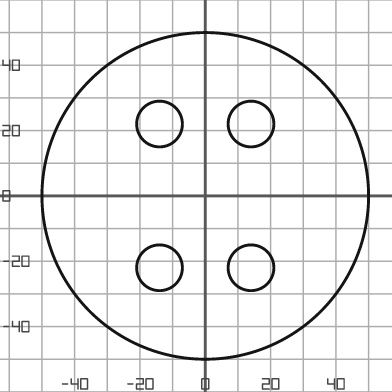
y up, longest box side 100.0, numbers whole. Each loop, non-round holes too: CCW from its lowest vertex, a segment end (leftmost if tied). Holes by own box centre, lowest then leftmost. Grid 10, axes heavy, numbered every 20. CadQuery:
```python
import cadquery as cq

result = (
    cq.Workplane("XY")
    .moveTo(0.0, 0.0)
    .circle(50.0)
    .moveTo(-14.0, -22.0)
    .circle(7.0)
    .moveTo(14.0, -22.0)
    .circle(7.0)
    .moveTo(-14.0, 22.0)
    .circle(7.0)
    .moveTo(14.0, 22.0)
    .circle(7.0)
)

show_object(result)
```